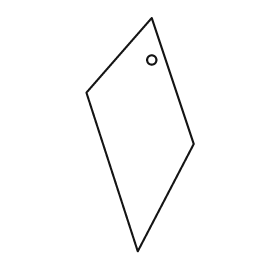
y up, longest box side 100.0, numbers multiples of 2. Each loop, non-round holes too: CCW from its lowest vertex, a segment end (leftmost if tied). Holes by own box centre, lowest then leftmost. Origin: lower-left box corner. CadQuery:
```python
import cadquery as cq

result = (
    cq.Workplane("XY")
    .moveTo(22.0, 0.0)
    .lineTo(46.0, 46.0)
    .lineTo(28.0, 100.0)
    .lineTo(0.0, 68.0)
    .close()
    .moveTo(28.0, 82.0)
    .circle(2.0)
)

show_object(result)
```